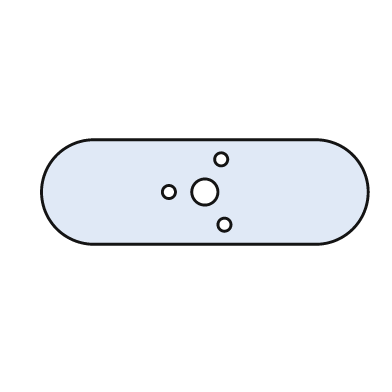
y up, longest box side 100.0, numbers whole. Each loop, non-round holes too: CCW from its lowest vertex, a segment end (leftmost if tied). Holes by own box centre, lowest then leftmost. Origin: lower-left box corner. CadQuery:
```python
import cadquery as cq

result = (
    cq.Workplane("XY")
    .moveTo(16.0, 0.0)
    .lineTo(84.0, 0.0)
    .threePointArc((100.0, 16.0), (84.0, 32.0))
    .lineTo(16.0, 32.0)
    .threePointArc((0.0, 16.0), (16.0, 0.0))
    .close()
    .moveTo(56.0, 6.0)
    .circle(2.0)
    .moveTo(39.0, 16.0)
    .circle(2.0)
    .moveTo(50.0, 16.0)
    .circle(4.0)
    .moveTo(55.0, 26.0)
    .circle(2.0)
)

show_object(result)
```